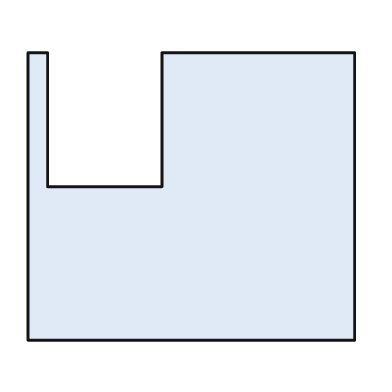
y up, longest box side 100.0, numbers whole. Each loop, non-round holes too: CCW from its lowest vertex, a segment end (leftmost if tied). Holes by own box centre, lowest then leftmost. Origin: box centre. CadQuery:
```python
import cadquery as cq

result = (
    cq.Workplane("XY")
    .moveTo(-50.0, -44.0)
    .lineTo(50.0, -44.0)
    .lineTo(50.0, 44.0)
    .lineTo(-9.0, 44.0)
    .lineTo(-9.0, 3.0)
    .lineTo(-44.0, 3.0)
    .lineTo(-44.0, 44.0)
    .lineTo(-50.0, 44.0)
    .close()
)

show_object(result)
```